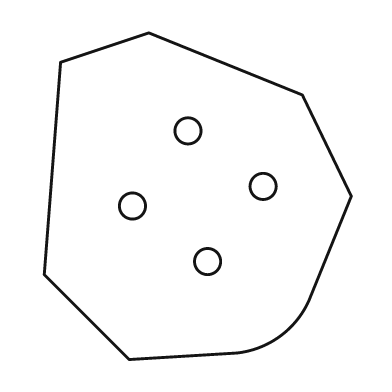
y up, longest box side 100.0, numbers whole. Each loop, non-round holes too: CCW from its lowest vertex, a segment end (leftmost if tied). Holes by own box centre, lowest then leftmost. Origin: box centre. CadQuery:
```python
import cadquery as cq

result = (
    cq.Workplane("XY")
    .moveTo(-21.0, -50.0)
    .lineTo(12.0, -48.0)
    .threePointArc((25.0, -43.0), (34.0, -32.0))
    .lineTo(47.0, 0.0)
    .lineTo(32.0, 31.0)
    .lineTo(-15.0, 50.0)
    .lineTo(-42.0, 41.0)
    .lineTo(-47.0, -24.0)
    .close()
    .moveTo(3.0, -20.0)
    .circle(4.0)
    .moveTo(-20.0, -3.0)
    .circle(4.0)
    .moveTo(20.0, 3.0)
    .circle(4.0)
    .moveTo(-3.0, 20.0)
    .circle(4.0)
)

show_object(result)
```